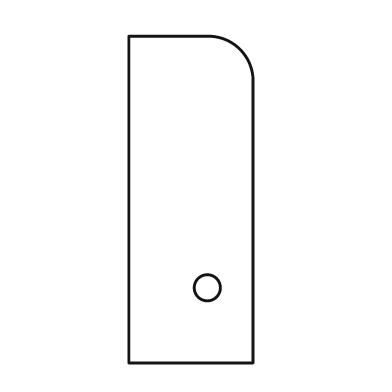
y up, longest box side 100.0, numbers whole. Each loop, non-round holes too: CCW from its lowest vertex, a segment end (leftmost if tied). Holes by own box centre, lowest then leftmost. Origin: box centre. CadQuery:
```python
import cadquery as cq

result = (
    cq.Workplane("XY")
    .moveTo(-19.0, -50.0)
    .lineTo(19.0, -50.0)
    .lineTo(19.0, 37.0)
    .threePointArc((15.0, 46.0), (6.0, 50.0))
    .lineTo(-19.0, 50.0)
    .close()
    .moveTo(5.0, -27.0)
    .circle(4.0)
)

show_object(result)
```